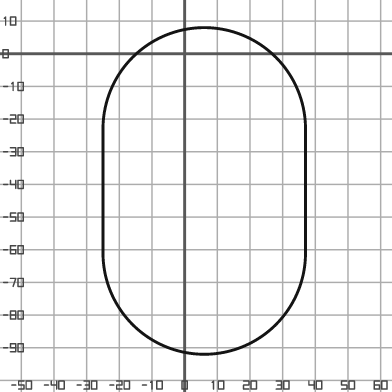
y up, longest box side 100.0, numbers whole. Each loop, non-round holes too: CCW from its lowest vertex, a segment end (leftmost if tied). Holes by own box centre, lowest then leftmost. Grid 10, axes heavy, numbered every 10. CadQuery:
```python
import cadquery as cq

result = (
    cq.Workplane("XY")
    .moveTo(-25.0, -61.0)
    .threePointArc((6.0, -92.0), (37.0, -61.0))
    .lineTo(37.0, -23.0)
    .threePointArc((6.0, 8.0), (-25.0, -23.0))
    .close()
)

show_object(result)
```